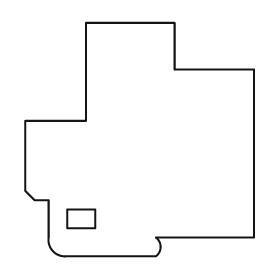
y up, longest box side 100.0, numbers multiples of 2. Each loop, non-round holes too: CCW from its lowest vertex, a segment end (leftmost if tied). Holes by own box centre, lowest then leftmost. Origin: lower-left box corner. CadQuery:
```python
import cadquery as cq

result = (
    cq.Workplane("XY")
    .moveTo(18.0, 0.0)
    .lineTo(56.0, 0.0)
    .threePointArc((58.0, 4.0), (56.0, 8.0))
    .lineTo(98.0, 8.0)
    .lineTo(98.0, 80.0)
    .lineTo(64.0, 80.0)
    .lineTo(64.0, 100.0)
    .lineTo(26.0, 100.0)
    .lineTo(26.0, 58.0)
    .lineTo(0.0, 58.0)
    .lineTo(0.0, 28.0)
    .lineTo(4.0, 24.0)
    .lineTo(10.0, 24.0)
    .lineTo(10.0, 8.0)
    .threePointArc((12.0, 2.0), (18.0, 0.0))
    .close()
    .moveTo(18.0, 12.0)
    .lineTo(30.0, 12.0)
    .lineTo(30.0, 20.0)
    .lineTo(18.0, 20.0)
    .close()
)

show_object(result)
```